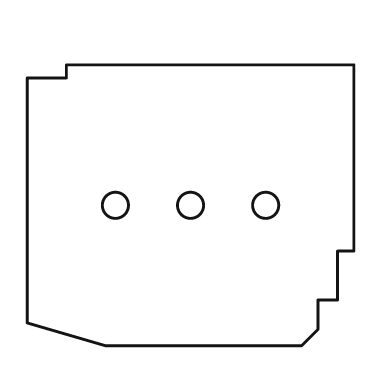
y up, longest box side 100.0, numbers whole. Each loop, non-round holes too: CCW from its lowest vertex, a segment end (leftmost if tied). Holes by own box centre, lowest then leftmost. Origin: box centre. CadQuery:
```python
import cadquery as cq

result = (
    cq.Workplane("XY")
    .moveTo(-26.0, -43.0)
    .lineTo(34.0, -43.0)
    .lineTo(39.0, -38.0)
    .lineTo(39.0, -29.0)
    .lineTo(45.0, -29.0)
    .lineTo(45.0, -14.0)
    .lineTo(50.0, -14.0)
    .lineTo(50.0, 43.0)
    .lineTo(-38.0, 43.0)
    .lineTo(-38.0, 39.0)
    .lineTo(-50.0, 39.0)
    .lineTo(-50.0, -36.0)
    .close()
    .moveTo(-23.0, 0.0)
    .circle(4.0)
    .moveTo(0.0, 0.0)
    .circle(4.0)
    .moveTo(23.0, 0.0)
    .circle(4.0)
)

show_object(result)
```